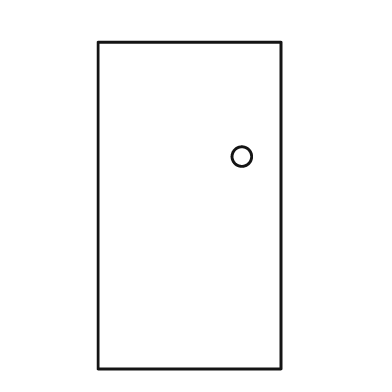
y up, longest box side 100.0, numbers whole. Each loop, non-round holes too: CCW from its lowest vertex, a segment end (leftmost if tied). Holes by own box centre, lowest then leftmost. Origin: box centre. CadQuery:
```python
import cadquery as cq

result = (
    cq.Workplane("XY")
    .moveTo(-28.0, -50.0)
    .lineTo(28.0, -50.0)
    .lineTo(28.0, 50.0)
    .lineTo(-28.0, 50.0)
    .close()
    .moveTo(16.0, 15.0)
    .circle(3.0)
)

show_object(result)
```